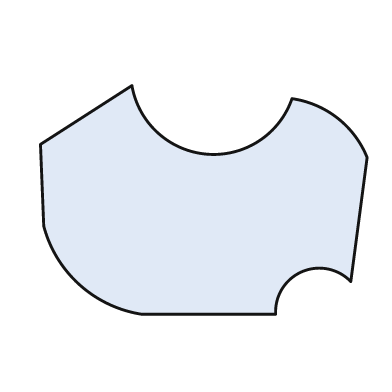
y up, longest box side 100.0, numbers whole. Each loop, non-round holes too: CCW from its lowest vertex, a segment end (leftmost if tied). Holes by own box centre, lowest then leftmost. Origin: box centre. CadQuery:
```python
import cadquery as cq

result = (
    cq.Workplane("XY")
    .moveTo(-19.0, -35.0)
    .lineTo(22.0, -35.0)
    .threePointArc((30.0, -22.0), (45.0, -25.0))
    .lineTo(50.0, 13.0)
    .threePointArc((41.0, 25.0), (27.0, 31.0))
    .threePointArc((1.0, 14.0), (-22.0, 35.0))
    .lineTo(-50.0, 17.0)
    .lineTo(-49.0, -8.0)
    .threePointArc((-38.0, -26.0), (-19.0, -35.0))
    .close()
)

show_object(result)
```